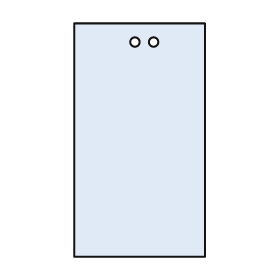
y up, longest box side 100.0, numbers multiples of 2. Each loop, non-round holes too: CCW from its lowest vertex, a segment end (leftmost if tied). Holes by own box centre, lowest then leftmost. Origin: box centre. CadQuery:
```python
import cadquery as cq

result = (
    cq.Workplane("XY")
    .moveTo(-28.0, -50.0)
    .lineTo(28.0, -50.0)
    .lineTo(28.0, 50.0)
    .lineTo(-28.0, 50.0)
    .close()
    .moveTo(-2.0, 42.0)
    .circle(2.0)
    .moveTo(6.0, 42.0)
    .circle(2.0)
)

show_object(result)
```